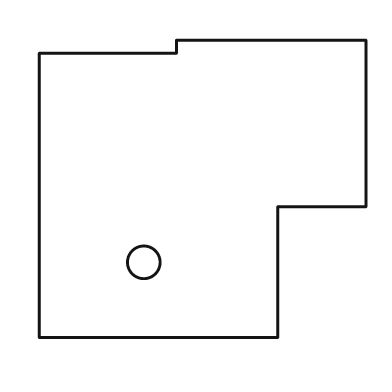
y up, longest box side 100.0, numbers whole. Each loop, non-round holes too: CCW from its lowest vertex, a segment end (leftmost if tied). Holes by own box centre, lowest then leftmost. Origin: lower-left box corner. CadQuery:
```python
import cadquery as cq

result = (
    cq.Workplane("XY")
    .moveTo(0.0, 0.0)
    .lineTo(73.0, 0.0)
    .lineTo(73.0, 40.0)
    .lineTo(100.0, 40.0)
    .lineTo(100.0, 91.0)
    .lineTo(42.0, 91.0)
    .lineTo(42.0, 87.0)
    .lineTo(0.0, 87.0)
    .close()
    .moveTo(32.0, 23.0)
    .circle(5.0)
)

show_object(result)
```